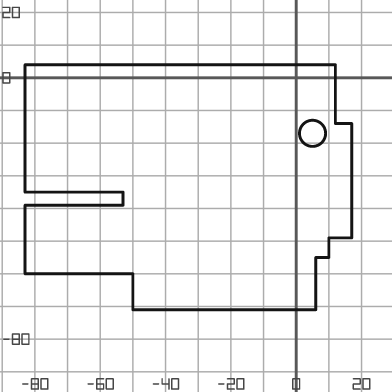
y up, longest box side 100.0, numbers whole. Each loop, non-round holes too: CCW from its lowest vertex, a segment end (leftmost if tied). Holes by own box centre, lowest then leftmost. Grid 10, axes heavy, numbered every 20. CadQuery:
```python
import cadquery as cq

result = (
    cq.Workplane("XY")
    .moveTo(-50.0, -71.0)
    .lineTo(6.0, -71.0)
    .lineTo(6.0, -55.0)
    .lineTo(10.0, -55.0)
    .lineTo(10.0, -49.0)
    .lineTo(17.0, -49.0)
    .lineTo(17.0, -14.0)
    .lineTo(12.0, -14.0)
    .lineTo(12.0, 4.0)
    .lineTo(-83.0, 4.0)
    .lineTo(-83.0, -35.0)
    .lineTo(-53.0, -35.0)
    .lineTo(-53.0, -39.0)
    .lineTo(-83.0, -39.0)
    .lineTo(-83.0, -60.0)
    .lineTo(-50.0, -60.0)
    .close()
    .moveTo(5.0, -17.0)
    .circle(4.0)
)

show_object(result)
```